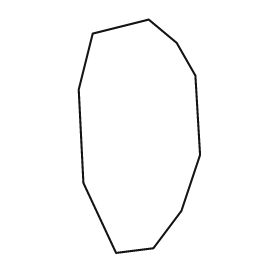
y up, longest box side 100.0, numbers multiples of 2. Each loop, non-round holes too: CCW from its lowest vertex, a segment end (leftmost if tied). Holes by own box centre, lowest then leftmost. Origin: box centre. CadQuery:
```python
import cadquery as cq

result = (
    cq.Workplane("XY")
    .moveTo(-10.0, -50.0)
    .lineTo(6.0, -48.0)
    .lineTo(18.0, -32.0)
    .lineTo(26.0, -8.0)
    .lineTo(24.0, 26.0)
    .lineTo(16.0, 40.0)
    .lineTo(4.0, 50.0)
    .lineTo(-20.0, 44.0)
    .lineTo(-26.0, 20.0)
    .lineTo(-24.0, -20.0)
    .close()
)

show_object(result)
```